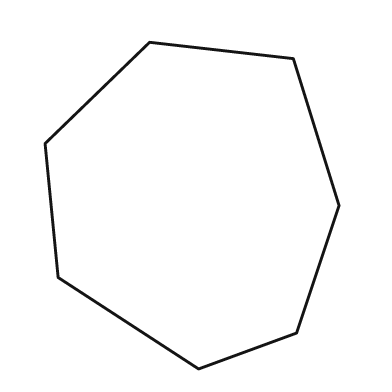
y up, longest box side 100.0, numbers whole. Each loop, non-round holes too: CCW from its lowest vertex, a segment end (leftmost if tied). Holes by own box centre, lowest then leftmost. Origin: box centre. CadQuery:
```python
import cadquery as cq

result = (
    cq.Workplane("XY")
    .moveTo(2.0, -50.0)
    .lineTo(32.0, -39.0)
    .lineTo(45.0, 0.0)
    .lineTo(31.0, 45.0)
    .lineTo(-13.0, 50.0)
    .lineTo(-45.0, 19.0)
    .lineTo(-41.0, -22.0)
    .close()
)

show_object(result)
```